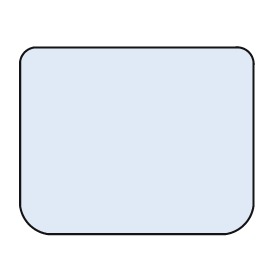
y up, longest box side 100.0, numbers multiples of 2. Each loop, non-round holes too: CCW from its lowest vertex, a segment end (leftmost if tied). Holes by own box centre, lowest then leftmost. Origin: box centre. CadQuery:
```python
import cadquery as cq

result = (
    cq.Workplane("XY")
    .moveTo(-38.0, -40.0)
    .lineTo(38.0, -40.0)
    .threePointArc((46.0, -36.0), (50.0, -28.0))
    .lineTo(50.0, 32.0)
    .threePointArc((48.0, 38.0), (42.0, 40.0))
    .lineTo(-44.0, 40.0)
    .threePointArc((-48.0, 38.0), (-50.0, 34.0))
    .lineTo(-50.0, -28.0)
    .threePointArc((-46.0, -36.0), (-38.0, -40.0))
    .close()
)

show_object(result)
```